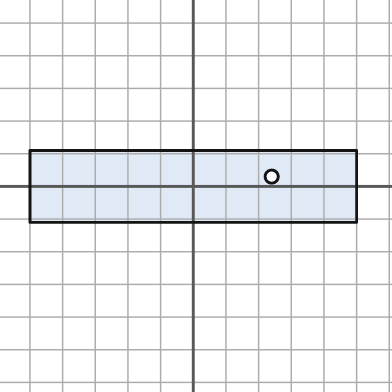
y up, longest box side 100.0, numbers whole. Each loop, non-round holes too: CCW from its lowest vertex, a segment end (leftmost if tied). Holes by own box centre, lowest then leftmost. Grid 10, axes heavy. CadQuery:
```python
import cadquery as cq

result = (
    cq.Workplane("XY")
    .moveTo(-50.0, -11.0)
    .lineTo(50.0, -11.0)
    .lineTo(50.0, 11.0)
    .lineTo(-50.0, 11.0)
    .close()
    .moveTo(24.0, 3.0)
    .circle(2.0)
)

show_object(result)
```